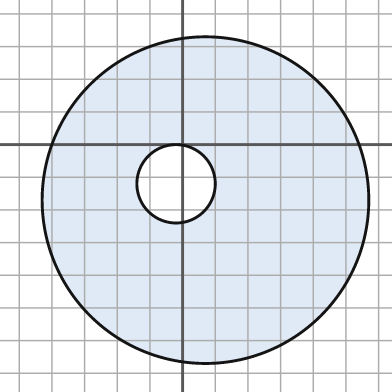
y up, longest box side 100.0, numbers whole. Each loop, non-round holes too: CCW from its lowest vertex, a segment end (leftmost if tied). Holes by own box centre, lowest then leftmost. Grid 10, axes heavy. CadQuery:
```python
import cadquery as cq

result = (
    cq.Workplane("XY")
    .moveTo(7.0, -17.0)
    .circle(50.0)
    .moveTo(-2.0, -12.0)
    .circle(12.0)
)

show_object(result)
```